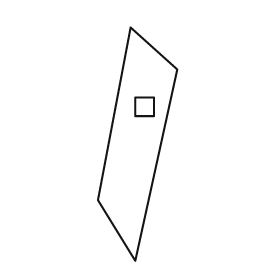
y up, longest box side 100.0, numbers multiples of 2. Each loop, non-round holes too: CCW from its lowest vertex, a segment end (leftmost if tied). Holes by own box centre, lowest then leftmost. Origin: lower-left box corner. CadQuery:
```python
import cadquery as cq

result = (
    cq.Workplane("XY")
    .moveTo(16.0, 0.0)
    .lineTo(34.0, 82.0)
    .lineTo(14.0, 100.0)
    .lineTo(0.0, 26.0)
    .close()
    .moveTo(16.0, 62.0)
    .lineTo(24.0, 62.0)
    .lineTo(24.0, 70.0)
    .lineTo(16.0, 70.0)
    .close()
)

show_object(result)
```